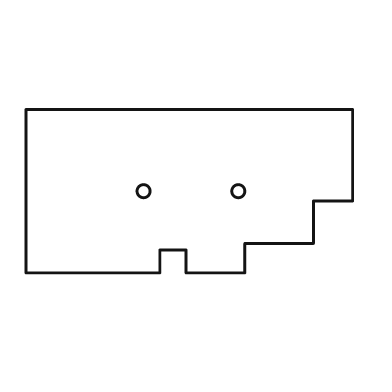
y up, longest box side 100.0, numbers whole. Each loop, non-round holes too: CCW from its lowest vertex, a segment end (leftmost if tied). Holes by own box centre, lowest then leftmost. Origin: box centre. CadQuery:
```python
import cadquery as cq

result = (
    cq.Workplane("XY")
    .moveTo(-50.0, -25.0)
    .lineTo(-9.0, -25.0)
    .lineTo(-9.0, -18.0)
    .lineTo(-1.0, -18.0)
    .lineTo(-1.0, -25.0)
    .lineTo(17.0, -25.0)
    .lineTo(17.0, -16.0)
    .lineTo(38.0, -16.0)
    .lineTo(38.0, -3.0)
    .lineTo(50.0, -3.0)
    .lineTo(50.0, 25.0)
    .lineTo(-50.0, 25.0)
    .close()
    .moveTo(-14.0, 0.0)
    .circle(2.0)
    .moveTo(15.0, 0.0)
    .circle(2.0)
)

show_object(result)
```